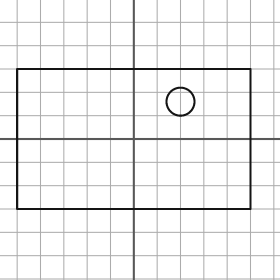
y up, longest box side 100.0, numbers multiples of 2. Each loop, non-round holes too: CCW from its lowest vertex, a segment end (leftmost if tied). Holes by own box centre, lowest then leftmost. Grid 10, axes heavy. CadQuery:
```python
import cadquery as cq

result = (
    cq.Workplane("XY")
    .moveTo(-50.0, -30.0)
    .lineTo(50.0, -30.0)
    .lineTo(50.0, 30.0)
    .lineTo(-50.0, 30.0)
    .close()
    .moveTo(20.0, 16.0)
    .circle(6.0)
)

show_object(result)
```